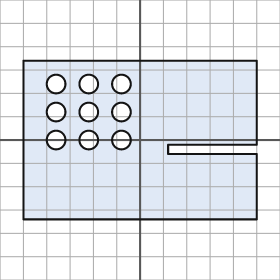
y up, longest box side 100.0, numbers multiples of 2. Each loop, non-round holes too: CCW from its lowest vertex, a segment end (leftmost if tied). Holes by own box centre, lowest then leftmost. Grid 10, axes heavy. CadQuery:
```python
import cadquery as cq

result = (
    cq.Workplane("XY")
    .moveTo(-50.0, -34.0)
    .lineTo(50.0, -34.0)
    .lineTo(50.0, -6.0)
    .lineTo(12.0, -6.0)
    .lineTo(12.0, -2.0)
    .lineTo(50.0, -2.0)
    .lineTo(50.0, 34.0)
    .lineTo(-50.0, 34.0)
    .close()
    .moveTo(-36.0, 0.0)
    .circle(4.0)
    .moveTo(-22.0, 0.0)
    .circle(4.0)
    .moveTo(-8.0, 0.0)
    .circle(4.0)
    .moveTo(-36.0, 12.0)
    .circle(4.0)
    .moveTo(-22.0, 12.0)
    .circle(4.0)
    .moveTo(-8.0, 12.0)
    .circle(4.0)
    .moveTo(-36.0, 24.0)
    .circle(4.0)
    .moveTo(-22.0, 24.0)
    .circle(4.0)
    .moveTo(-8.0, 24.0)
    .circle(4.0)
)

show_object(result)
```